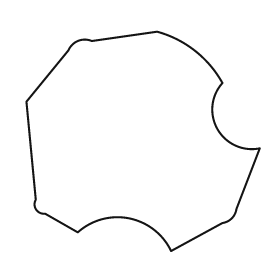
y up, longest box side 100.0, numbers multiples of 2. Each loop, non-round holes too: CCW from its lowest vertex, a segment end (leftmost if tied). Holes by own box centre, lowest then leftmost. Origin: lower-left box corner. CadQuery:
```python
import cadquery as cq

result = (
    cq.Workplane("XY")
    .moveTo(62.0, 0.0)
    .lineTo(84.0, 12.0)
    .threePointArc((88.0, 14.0), (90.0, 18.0))
    .lineTo(100.0, 44.0)
    .threePointArc((82.0, 52.0), (84.0, 72.0))
    .threePointArc((72.0, 86.0), (56.0, 94.0))
    .lineTo(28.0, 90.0)
    .threePointArc((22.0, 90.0), (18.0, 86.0))
    .lineTo(0.0, 64.0)
    .lineTo(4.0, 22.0)
    .threePointArc((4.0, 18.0), (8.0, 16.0))
    .lineTo(22.0, 8.0)
    .threePointArc((44.0, 14.0), (62.0, 0.0))
    .close()
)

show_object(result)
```